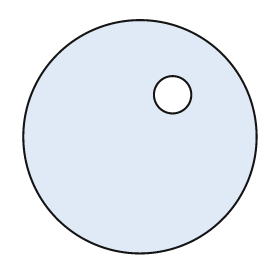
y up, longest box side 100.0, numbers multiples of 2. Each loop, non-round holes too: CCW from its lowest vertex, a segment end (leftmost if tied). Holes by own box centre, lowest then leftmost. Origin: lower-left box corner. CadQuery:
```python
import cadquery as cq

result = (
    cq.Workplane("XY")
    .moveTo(50.0, 50.0)
    .circle(50.0)
    .moveTo(64.0, 68.0)
    .circle(8.0)
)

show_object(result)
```